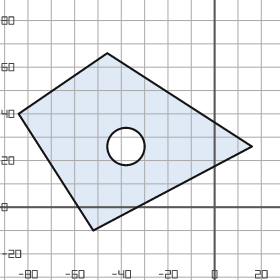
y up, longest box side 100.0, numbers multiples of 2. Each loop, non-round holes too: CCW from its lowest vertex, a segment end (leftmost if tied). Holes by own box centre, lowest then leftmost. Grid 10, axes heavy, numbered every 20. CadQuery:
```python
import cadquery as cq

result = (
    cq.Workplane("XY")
    .moveTo(-52.0, -10.0)
    .lineTo(16.0, 26.0)
    .lineTo(-46.0, 66.0)
    .lineTo(-84.0, 40.0)
    .close()
    .moveTo(-38.0, 26.0)
    .circle(8.0)
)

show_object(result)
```